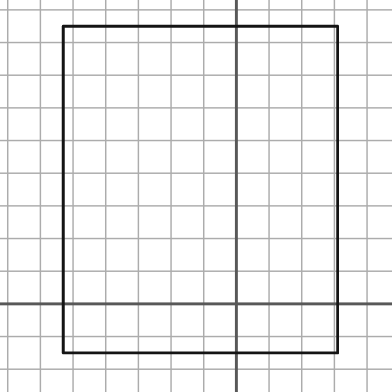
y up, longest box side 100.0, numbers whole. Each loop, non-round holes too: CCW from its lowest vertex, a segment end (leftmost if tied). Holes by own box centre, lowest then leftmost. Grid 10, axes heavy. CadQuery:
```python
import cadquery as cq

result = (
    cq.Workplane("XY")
    .moveTo(-53.0, -15.0)
    .lineTo(31.0, -15.0)
    .lineTo(31.0, 85.0)
    .lineTo(-53.0, 85.0)
    .close()
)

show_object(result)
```